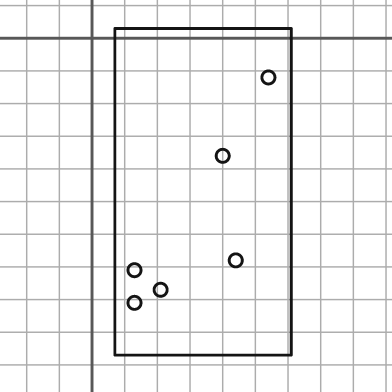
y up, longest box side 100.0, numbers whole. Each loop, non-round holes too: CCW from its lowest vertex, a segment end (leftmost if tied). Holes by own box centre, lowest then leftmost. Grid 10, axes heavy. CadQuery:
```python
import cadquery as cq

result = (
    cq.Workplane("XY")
    .moveTo(7.0, -97.0)
    .lineTo(61.0, -97.0)
    .lineTo(61.0, 3.0)
    .lineTo(7.0, 3.0)
    .close()
    .moveTo(13.0, -81.0)
    .circle(2.0)
    .moveTo(21.0, -77.0)
    .circle(2.0)
    .moveTo(13.0, -71.0)
    .circle(2.0)
    .moveTo(44.0, -68.0)
    .circle(2.0)
    .moveTo(40.0, -36.0)
    .circle(2.0)
    .moveTo(54.0, -12.0)
    .circle(2.0)
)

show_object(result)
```